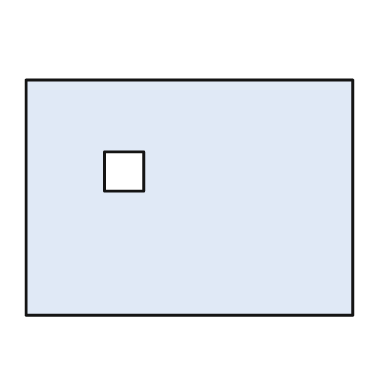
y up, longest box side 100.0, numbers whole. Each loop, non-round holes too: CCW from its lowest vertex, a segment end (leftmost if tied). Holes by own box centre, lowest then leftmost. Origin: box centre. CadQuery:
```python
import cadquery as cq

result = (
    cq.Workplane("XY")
    .moveTo(-50.0, -36.0)
    .lineTo(50.0, -36.0)
    .lineTo(50.0, 36.0)
    .lineTo(-50.0, 36.0)
    .close()
    .moveTo(-26.0, 2.0)
    .lineTo(-14.0, 2.0)
    .lineTo(-14.0, 14.0)
    .lineTo(-26.0, 14.0)
    .close()
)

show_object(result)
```